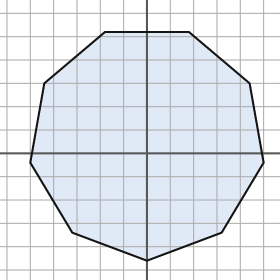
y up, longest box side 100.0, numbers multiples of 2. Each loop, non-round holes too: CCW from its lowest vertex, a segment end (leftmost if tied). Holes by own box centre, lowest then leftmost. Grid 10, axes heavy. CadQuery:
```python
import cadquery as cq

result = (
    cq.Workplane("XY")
    .moveTo(0.0, -46.0)
    .lineTo(32.0, -34.0)
    .lineTo(50.0, -4.0)
    .lineTo(44.0, 30.0)
    .lineTo(18.0, 52.0)
    .lineTo(-18.0, 52.0)
    .lineTo(-44.0, 30.0)
    .lineTo(-50.0, -4.0)
    .lineTo(-32.0, -34.0)
    .close()
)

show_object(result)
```